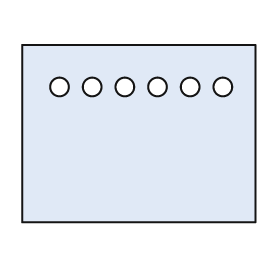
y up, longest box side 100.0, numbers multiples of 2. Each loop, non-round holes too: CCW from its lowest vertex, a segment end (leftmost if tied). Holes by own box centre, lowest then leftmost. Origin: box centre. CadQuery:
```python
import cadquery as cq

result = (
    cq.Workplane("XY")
    .moveTo(-50.0, -38.0)
    .lineTo(50.0, -38.0)
    .lineTo(50.0, 38.0)
    .lineTo(-50.0, 38.0)
    .close()
    .moveTo(-34.0, 20.0)
    .circle(4.0)
    .moveTo(-20.0, 20.0)
    .circle(4.0)
    .moveTo(-6.0, 20.0)
    .circle(4.0)
    .moveTo(8.0, 20.0)
    .circle(4.0)
    .moveTo(22.0, 20.0)
    .circle(4.0)
    .moveTo(36.0, 20.0)
    .circle(4.0)
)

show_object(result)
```